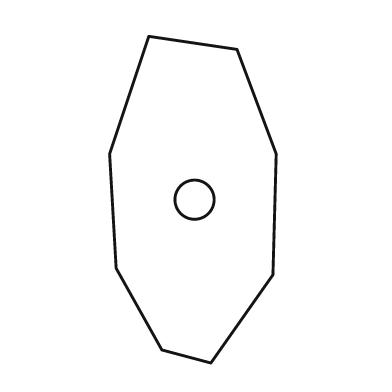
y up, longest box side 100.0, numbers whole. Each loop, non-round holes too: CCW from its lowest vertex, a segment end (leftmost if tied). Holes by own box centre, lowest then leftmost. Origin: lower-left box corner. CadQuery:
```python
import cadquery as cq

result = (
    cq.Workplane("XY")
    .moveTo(31.0, 0.0)
    .lineTo(50.0, 27.0)
    .lineTo(51.0, 64.0)
    .lineTo(39.0, 96.0)
    .lineTo(12.0, 100.0)
    .lineTo(0.0, 64.0)
    .lineTo(2.0, 29.0)
    .lineTo(16.0, 4.0)
    .close()
    .moveTo(26.0, 50.0)
    .circle(6.0)
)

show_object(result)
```